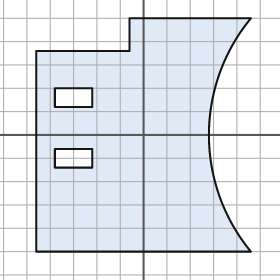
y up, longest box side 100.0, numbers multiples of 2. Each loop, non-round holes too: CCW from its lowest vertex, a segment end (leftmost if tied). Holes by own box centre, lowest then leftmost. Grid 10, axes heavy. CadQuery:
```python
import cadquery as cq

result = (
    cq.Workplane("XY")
    .moveTo(-46.0, -50.0)
    .lineTo(46.0, -50.0)
    .threePointArc((28.0, 0.0), (46.0, 50.0))
    .lineTo(-6.0, 50.0)
    .lineTo(-6.0, 36.0)
    .lineTo(-46.0, 36.0)
    .close()
    .moveTo(-38.0, -14.0)
    .lineTo(-22.0, -14.0)
    .lineTo(-22.0, -6.0)
    .lineTo(-38.0, -6.0)
    .close()
    .moveTo(-38.0, 12.0)
    .lineTo(-22.0, 12.0)
    .lineTo(-22.0, 20.0)
    .lineTo(-38.0, 20.0)
    .close()
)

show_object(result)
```